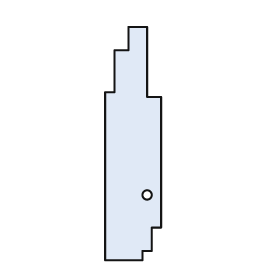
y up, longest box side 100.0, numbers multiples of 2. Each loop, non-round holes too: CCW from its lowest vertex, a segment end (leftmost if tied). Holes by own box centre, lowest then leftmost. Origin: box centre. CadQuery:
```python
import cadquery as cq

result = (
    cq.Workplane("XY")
    .moveTo(-12.0, -50.0)
    .lineTo(4.0, -50.0)
    .lineTo(4.0, -46.0)
    .lineTo(8.0, -46.0)
    .lineTo(8.0, -36.0)
    .lineTo(12.0, -36.0)
    .lineTo(12.0, 20.0)
    .lineTo(6.0, 20.0)
    .lineTo(6.0, 50.0)
    .lineTo(-2.0, 50.0)
    .lineTo(-2.0, 40.0)
    .lineTo(-8.0, 40.0)
    .lineTo(-8.0, 22.0)
    .lineTo(-12.0, 22.0)
    .close()
    .moveTo(6.0, -22.0)
    .circle(2.0)
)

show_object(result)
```